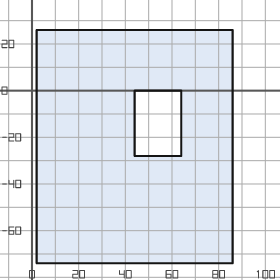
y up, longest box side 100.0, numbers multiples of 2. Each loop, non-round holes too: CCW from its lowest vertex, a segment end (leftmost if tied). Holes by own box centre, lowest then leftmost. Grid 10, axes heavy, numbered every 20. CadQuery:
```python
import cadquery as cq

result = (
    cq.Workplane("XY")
    .moveTo(2.0, -74.0)
    .lineTo(86.0, -74.0)
    .lineTo(86.0, 26.0)
    .lineTo(2.0, 26.0)
    .close()
    .moveTo(44.0, -28.0)
    .lineTo(64.0, -28.0)
    .lineTo(64.0, 0.0)
    .lineTo(44.0, 0.0)
    .close()
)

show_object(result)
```